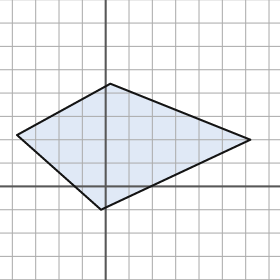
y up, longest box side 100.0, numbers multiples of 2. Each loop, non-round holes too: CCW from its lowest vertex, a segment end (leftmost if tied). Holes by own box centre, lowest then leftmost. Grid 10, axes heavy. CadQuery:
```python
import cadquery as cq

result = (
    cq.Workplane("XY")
    .moveTo(-2.0, -10.0)
    .lineTo(62.0, 20.0)
    .lineTo(2.0, 44.0)
    .lineTo(-38.0, 22.0)
    .close()
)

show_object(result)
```